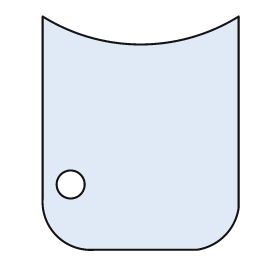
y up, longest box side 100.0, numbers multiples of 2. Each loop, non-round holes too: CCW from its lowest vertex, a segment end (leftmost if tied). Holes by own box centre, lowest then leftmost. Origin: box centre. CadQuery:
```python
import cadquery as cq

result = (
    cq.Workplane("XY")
    .moveTo(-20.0, -50.0)
    .lineTo(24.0, -50.0)
    .threePointArc((36.0, -44.0), (42.0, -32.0))
    .lineTo(42.0, 50.0)
    .threePointArc((0.0, 38.0), (-42.0, 50.0))
    .lineTo(-42.0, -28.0)
    .threePointArc((-36.0, -44.0), (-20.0, -50.0))
    .close()
    .moveTo(-30.0, -22.0)
    .circle(6.0)
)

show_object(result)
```